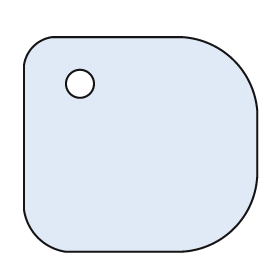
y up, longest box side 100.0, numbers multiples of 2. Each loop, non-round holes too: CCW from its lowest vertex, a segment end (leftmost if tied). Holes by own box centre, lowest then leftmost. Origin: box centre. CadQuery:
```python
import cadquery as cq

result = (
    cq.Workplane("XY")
    .moveTo(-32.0, -46.0)
    .lineTo(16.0, -46.0)
    .threePointArc((40.0, -36.0), (50.0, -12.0))
    .lineTo(50.0, 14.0)
    .threePointArc((40.0, 36.0), (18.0, 46.0))
    .lineTo(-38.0, 46.0)
    .threePointArc((-46.0, 42.0), (-50.0, 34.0))
    .lineTo(-50.0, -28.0)
    .threePointArc((-44.0, -40.0), (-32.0, -46.0))
    .close()
    .moveTo(-26.0, 26.0)
    .circle(6.0)
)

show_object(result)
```